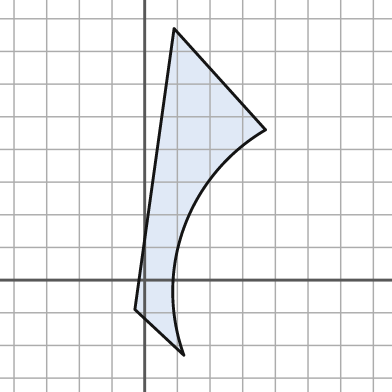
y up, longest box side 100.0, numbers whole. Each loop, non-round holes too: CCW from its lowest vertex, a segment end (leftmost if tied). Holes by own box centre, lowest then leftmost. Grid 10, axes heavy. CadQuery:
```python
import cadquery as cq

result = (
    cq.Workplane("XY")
    .moveTo(12.0, -23.0)
    .threePointArc((12.0, 16.0), (37.0, 46.0))
    .lineTo(9.0, 77.0)
    .lineTo(-3.0, -9.0)
    .close()
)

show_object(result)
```